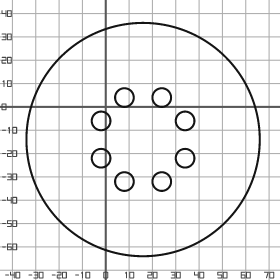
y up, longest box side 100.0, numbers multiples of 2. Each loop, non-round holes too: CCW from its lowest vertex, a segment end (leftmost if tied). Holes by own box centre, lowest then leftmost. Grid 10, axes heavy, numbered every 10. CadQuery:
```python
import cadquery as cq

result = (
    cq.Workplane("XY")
    .moveTo(16.0, -14.0)
    .circle(50.0)
    .moveTo(8.0, -32.0)
    .circle(4.0)
    .moveTo(24.0, -32.0)
    .circle(4.0)
    .moveTo(-2.0, -22.0)
    .circle(4.0)
    .moveTo(34.0, -22.0)
    .circle(4.0)
    .moveTo(-2.0, -6.0)
    .circle(4.0)
    .moveTo(34.0, -6.0)
    .circle(4.0)
    .moveTo(8.0, 4.0)
    .circle(4.0)
    .moveTo(24.0, 4.0)
    .circle(4.0)
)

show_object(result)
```